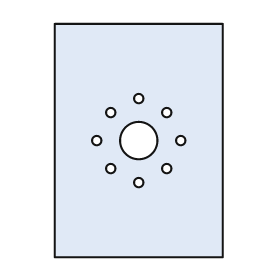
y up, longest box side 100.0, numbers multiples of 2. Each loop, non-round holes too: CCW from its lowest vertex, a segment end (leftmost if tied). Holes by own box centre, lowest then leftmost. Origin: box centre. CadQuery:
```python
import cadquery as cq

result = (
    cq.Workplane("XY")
    .moveTo(-36.0, -50.0)
    .lineTo(36.0, -50.0)
    .lineTo(36.0, 50.0)
    .lineTo(-36.0, 50.0)
    .close()
    .moveTo(0.0, -18.0)
    .circle(2.0)
    .moveTo(-12.0, -12.0)
    .circle(2.0)
    .moveTo(12.0, -12.0)
    .circle(2.0)
    .moveTo(-18.0, 0.0)
    .circle(2.0)
    .moveTo(0.0, 0.0)
    .circle(8.0)
    .moveTo(18.0, 0.0)
    .circle(2.0)
    .moveTo(-12.0, 12.0)
    .circle(2.0)
    .moveTo(12.0, 12.0)
    .circle(2.0)
    .moveTo(0.0, 18.0)
    .circle(2.0)
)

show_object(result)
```